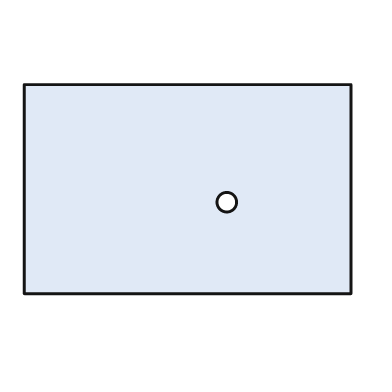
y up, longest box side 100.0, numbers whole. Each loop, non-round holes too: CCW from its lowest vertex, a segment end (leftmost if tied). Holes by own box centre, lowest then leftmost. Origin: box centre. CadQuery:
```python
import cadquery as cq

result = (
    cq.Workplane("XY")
    .moveTo(-50.0, -32.0)
    .lineTo(50.0, -32.0)
    .lineTo(50.0, 32.0)
    .lineTo(-50.0, 32.0)
    .close()
    .moveTo(12.0, -4.0)
    .circle(3.0)
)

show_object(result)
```